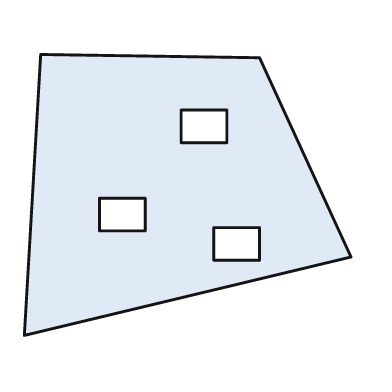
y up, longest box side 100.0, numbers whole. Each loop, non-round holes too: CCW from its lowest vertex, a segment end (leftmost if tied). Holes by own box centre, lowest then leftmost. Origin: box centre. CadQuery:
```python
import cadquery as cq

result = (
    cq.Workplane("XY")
    .moveTo(-50.0, -43.0)
    .lineTo(50.0, -19.0)
    .lineTo(22.0, 42.0)
    .lineTo(-45.0, 43.0)
    .close()
    .moveTo(8.0, -20.0)
    .lineTo(22.0, -20.0)
    .lineTo(22.0, -10.0)
    .lineTo(8.0, -10.0)
    .close()
    .moveTo(-27.0, -11.0)
    .lineTo(-13.0, -11.0)
    .lineTo(-13.0, -1.0)
    .lineTo(-27.0, -1.0)
    .close()
    .moveTo(-2.0, 16.0)
    .lineTo(12.0, 16.0)
    .lineTo(12.0, 26.0)
    .lineTo(-2.0, 26.0)
    .close()
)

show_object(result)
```